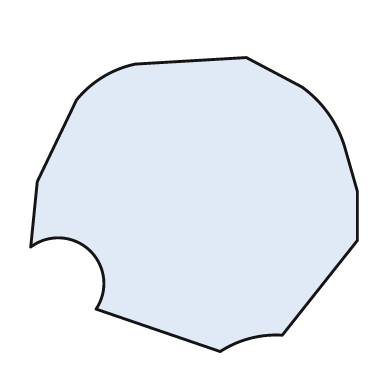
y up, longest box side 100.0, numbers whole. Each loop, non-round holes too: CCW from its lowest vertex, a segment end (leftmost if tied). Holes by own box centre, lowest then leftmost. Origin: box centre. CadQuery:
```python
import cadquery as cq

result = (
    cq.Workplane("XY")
    .moveTo(8.0, -45.0)
    .threePointArc((17.0, -41.0), (27.0, -40.0))
    .lineTo(50.0, -11.0)
    .lineTo(50.0, 4.0)
    .lineTo(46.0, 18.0)
    .threePointArc((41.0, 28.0), (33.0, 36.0))
    .lineTo(16.0, 45.0)
    .lineTo(-18.0, 43.0)
    .threePointArc((-28.0, 39.0), (-36.0, 32.0))
    .lineTo(-48.0, 7.0)
    .lineTo(-50.0, -13.0)
    .threePointArc((-32.0, -14.0), (-30.0, -32.0))
    .close()
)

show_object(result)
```